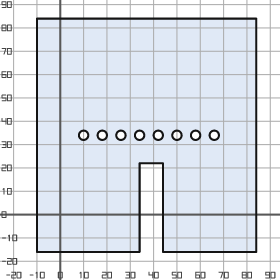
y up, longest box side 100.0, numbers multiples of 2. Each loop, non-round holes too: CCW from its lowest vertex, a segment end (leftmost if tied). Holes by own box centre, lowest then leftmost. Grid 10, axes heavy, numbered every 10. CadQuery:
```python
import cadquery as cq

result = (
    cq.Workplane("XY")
    .moveTo(-10.0, -16.0)
    .lineTo(34.0, -16.0)
    .lineTo(34.0, 22.0)
    .lineTo(44.0, 22.0)
    .lineTo(44.0, -16.0)
    .lineTo(84.0, -16.0)
    .lineTo(84.0, 84.0)
    .lineTo(-10.0, 84.0)
    .close()
    .moveTo(10.0, 34.0)
    .circle(2.0)
    .moveTo(18.0, 34.0)
    .circle(2.0)
    .moveTo(26.0, 34.0)
    .circle(2.0)
    .moveTo(34.0, 34.0)
    .circle(2.0)
    .moveTo(42.0, 34.0)
    .circle(2.0)
    .moveTo(50.0, 34.0)
    .circle(2.0)
    .moveTo(58.0, 34.0)
    .circle(2.0)
    .moveTo(66.0, 34.0)
    .circle(2.0)
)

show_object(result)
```